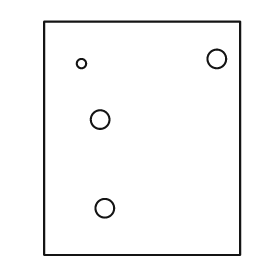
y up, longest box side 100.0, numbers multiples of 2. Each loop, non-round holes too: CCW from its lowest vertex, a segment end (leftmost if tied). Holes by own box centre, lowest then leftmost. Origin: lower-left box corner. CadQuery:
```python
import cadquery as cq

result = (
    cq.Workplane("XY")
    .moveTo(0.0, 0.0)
    .lineTo(84.0, 0.0)
    .lineTo(84.0, 100.0)
    .lineTo(0.0, 100.0)
    .close()
    .moveTo(26.0, 20.0)
    .circle(4.0)
    .moveTo(24.0, 58.0)
    .circle(4.0)
    .moveTo(16.0, 82.0)
    .circle(2.0)
    .moveTo(74.0, 84.0)
    .circle(4.0)
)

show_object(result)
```